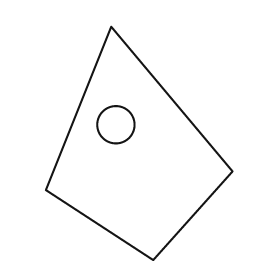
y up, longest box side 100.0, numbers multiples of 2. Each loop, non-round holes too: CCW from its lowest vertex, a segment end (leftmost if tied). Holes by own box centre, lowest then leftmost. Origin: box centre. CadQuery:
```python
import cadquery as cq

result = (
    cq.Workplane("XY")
    .moveTo(6.0, -50.0)
    .lineTo(40.0, -12.0)
    .lineTo(-12.0, 50.0)
    .lineTo(-40.0, -20.0)
    .close()
    .moveTo(-10.0, 8.0)
    .circle(8.0)
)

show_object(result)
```